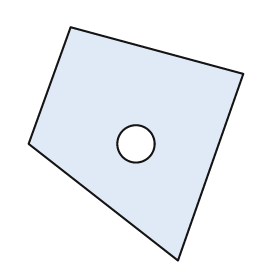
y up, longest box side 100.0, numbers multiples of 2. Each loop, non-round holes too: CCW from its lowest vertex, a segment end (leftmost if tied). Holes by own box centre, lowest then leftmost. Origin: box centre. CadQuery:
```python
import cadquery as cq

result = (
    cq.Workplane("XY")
    .moveTo(18.0, -50.0)
    .lineTo(46.0, 30.0)
    .lineTo(-28.0, 50.0)
    .lineTo(-46.0, 0.0)
    .close()
    .moveTo(0.0, 0.0)
    .circle(8.0)
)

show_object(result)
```